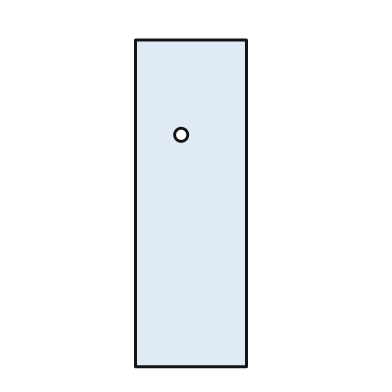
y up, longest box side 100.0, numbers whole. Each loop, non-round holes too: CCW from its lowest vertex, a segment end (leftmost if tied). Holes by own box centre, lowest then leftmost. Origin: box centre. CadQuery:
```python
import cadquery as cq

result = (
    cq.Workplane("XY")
    .moveTo(-17.0, -50.0)
    .lineTo(17.0, -50.0)
    .lineTo(17.0, 50.0)
    .lineTo(-17.0, 50.0)
    .close()
    .moveTo(-3.0, 21.0)
    .circle(2.0)
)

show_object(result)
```